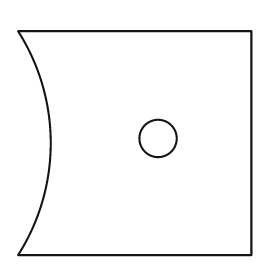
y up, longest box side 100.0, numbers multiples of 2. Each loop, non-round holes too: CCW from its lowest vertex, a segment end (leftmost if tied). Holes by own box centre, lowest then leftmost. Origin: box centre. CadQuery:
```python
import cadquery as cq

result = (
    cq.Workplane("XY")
    .moveTo(-50.0, -48.0)
    .lineTo(50.0, -48.0)
    .lineTo(50.0, 48.0)
    .lineTo(-50.0, 48.0)
    .threePointArc((-36.0, 0.0), (-50.0, -48.0))
    .close()
    .moveTo(10.0, 2.0)
    .circle(8.0)
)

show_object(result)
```